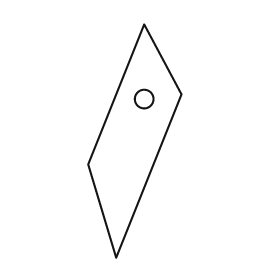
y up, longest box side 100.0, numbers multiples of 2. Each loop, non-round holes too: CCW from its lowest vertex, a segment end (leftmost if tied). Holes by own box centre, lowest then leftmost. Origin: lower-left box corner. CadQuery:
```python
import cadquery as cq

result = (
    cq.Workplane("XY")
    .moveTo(12.0, 0.0)
    .lineTo(40.0, 70.0)
    .lineTo(24.0, 100.0)
    .lineTo(0.0, 40.0)
    .close()
    .moveTo(24.0, 68.0)
    .circle(4.0)
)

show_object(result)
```